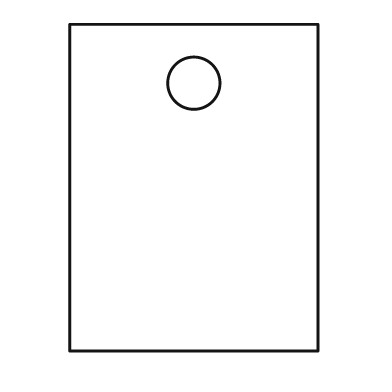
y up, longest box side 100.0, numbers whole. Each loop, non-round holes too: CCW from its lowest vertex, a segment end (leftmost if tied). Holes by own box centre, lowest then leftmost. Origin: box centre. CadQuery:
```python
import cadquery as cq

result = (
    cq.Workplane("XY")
    .moveTo(-38.0, -50.0)
    .lineTo(38.0, -50.0)
    .lineTo(38.0, 50.0)
    .lineTo(-38.0, 50.0)
    .close()
    .moveTo(0.0, 32.0)
    .circle(8.0)
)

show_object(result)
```